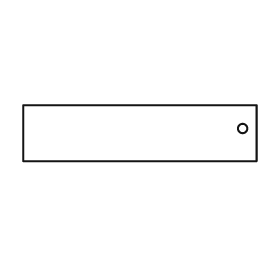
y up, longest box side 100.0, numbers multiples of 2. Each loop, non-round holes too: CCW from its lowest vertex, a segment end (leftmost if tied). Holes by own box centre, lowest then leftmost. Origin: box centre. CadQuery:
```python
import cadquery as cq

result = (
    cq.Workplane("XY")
    .moveTo(-50.0, -12.0)
    .lineTo(50.0, -12.0)
    .lineTo(50.0, 12.0)
    .lineTo(-50.0, 12.0)
    .close()
    .moveTo(44.0, 2.0)
    .circle(2.0)
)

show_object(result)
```